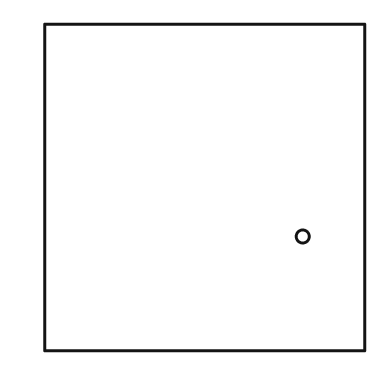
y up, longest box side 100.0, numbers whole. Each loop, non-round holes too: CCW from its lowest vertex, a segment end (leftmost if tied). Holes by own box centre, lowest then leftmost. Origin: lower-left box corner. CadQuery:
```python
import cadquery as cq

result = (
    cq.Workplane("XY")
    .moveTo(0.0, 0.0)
    .lineTo(98.0, 0.0)
    .lineTo(98.0, 100.0)
    .lineTo(0.0, 100.0)
    .close()
    .moveTo(79.0, 35.0)
    .circle(2.0)
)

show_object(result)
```